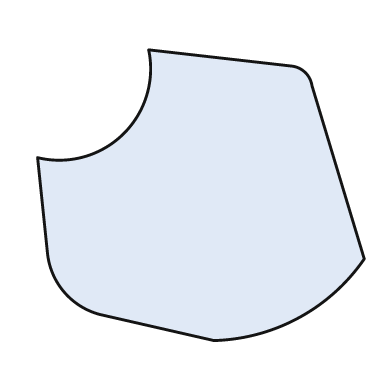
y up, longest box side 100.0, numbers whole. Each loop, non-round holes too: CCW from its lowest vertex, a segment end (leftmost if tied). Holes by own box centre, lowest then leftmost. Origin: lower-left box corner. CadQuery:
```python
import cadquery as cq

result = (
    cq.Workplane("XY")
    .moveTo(54.0, 0.0)
    .threePointArc((80.0, 7.0), (100.0, 25.0))
    .lineTo(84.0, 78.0)
    .threePointArc((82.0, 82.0), (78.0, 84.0))
    .lineTo(34.0, 89.0)
    .threePointArc((26.0, 63.0), (0.0, 56.0))
    .lineTo(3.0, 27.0)
    .threePointArc((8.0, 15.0), (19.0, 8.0))
    .close()
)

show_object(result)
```